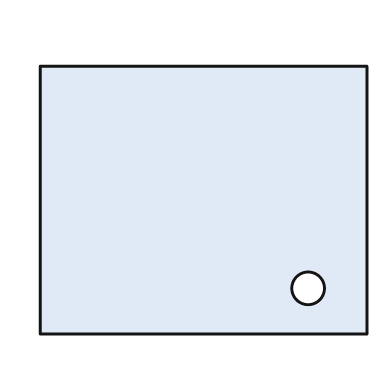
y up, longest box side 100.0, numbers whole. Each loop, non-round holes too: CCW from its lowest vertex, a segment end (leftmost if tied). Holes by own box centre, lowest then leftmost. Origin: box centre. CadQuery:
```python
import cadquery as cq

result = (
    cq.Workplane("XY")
    .moveTo(-50.0, -41.0)
    .lineTo(50.0, -41.0)
    .lineTo(50.0, 41.0)
    .lineTo(-50.0, 41.0)
    .close()
    .moveTo(32.0, -27.0)
    .circle(5.0)
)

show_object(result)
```